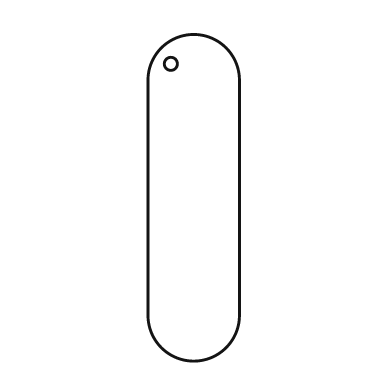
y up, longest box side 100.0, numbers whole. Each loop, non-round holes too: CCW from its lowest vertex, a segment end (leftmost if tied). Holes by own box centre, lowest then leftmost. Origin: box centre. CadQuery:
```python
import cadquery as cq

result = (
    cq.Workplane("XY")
    .moveTo(-14.0, -36.0)
    .threePointArc((0.0, -50.0), (14.0, -36.0))
    .lineTo(14.0, 36.0)
    .threePointArc((0.0, 50.0), (-14.0, 36.0))
    .close()
    .moveTo(-7.0, 41.0)
    .circle(2.0)
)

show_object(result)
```